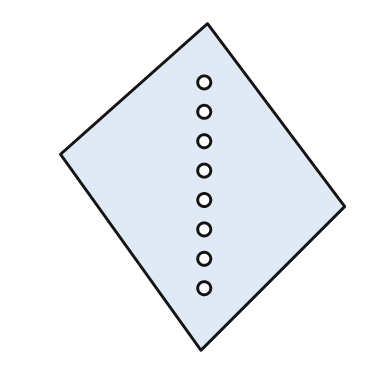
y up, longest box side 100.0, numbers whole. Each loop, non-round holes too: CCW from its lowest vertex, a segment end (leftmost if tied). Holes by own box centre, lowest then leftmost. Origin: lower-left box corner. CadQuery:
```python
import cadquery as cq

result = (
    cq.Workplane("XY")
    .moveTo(43.0, 0.0)
    .lineTo(87.0, 44.0)
    .lineTo(45.0, 100.0)
    .lineTo(0.0, 60.0)
    .close()
    .moveTo(44.0, 19.0)
    .circle(2.0)
    .moveTo(44.0, 28.0)
    .circle(2.0)
    .moveTo(44.0, 37.0)
    .circle(2.0)
    .moveTo(44.0, 46.0)
    .circle(2.0)
    .moveTo(44.0, 55.0)
    .circle(2.0)
    .moveTo(44.0, 64.0)
    .circle(2.0)
    .moveTo(44.0, 73.0)
    .circle(2.0)
    .moveTo(44.0, 82.0)
    .circle(2.0)
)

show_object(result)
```